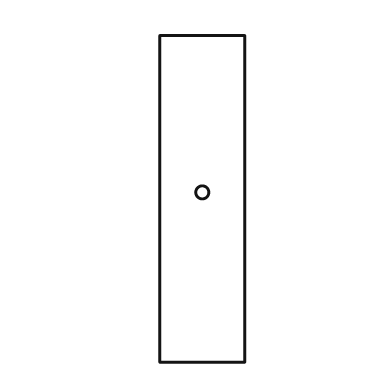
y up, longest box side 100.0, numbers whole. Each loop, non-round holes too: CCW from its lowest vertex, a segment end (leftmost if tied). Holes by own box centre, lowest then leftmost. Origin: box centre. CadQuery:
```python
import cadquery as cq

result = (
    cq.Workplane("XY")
    .moveTo(-13.0, -50.0)
    .lineTo(13.0, -50.0)
    .lineTo(13.0, 50.0)
    .lineTo(-13.0, 50.0)
    .close()
    .moveTo(0.0, 2.0)
    .circle(2.0)
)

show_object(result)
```